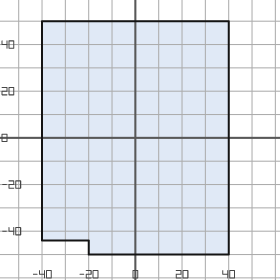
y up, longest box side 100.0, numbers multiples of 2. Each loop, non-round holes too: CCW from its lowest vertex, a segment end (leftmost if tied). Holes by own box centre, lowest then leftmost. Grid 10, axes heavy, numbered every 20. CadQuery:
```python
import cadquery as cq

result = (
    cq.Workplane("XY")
    .moveTo(-20.0, -50.0)
    .lineTo(40.0, -50.0)
    .lineTo(40.0, 50.0)
    .lineTo(-40.0, 50.0)
    .lineTo(-40.0, -44.0)
    .lineTo(-20.0, -44.0)
    .close()
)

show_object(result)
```